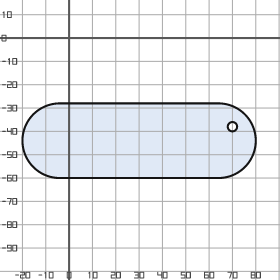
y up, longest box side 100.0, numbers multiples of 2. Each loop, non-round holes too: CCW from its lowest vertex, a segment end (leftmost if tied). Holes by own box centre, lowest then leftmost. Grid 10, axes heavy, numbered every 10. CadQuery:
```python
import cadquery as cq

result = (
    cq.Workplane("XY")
    .moveTo(-4.0, -60.0)
    .lineTo(64.0, -60.0)
    .threePointArc((80.0, -44.0), (64.0, -28.0))
    .lineTo(-4.0, -28.0)
    .threePointArc((-20.0, -44.0), (-4.0, -60.0))
    .close()
    .moveTo(70.0, -38.0)
    .circle(2.0)
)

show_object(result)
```